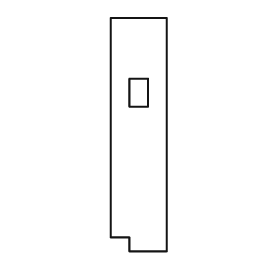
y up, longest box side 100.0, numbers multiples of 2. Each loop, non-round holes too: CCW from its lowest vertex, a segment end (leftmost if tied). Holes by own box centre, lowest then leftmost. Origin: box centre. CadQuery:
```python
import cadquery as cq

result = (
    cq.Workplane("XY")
    .moveTo(-4.0, -50.0)
    .lineTo(12.0, -50.0)
    .lineTo(12.0, 50.0)
    .lineTo(-12.0, 50.0)
    .lineTo(-12.0, -44.0)
    .lineTo(-4.0, -44.0)
    .close()
    .moveTo(-4.0, 12.0)
    .lineTo(4.0, 12.0)
    .lineTo(4.0, 24.0)
    .lineTo(-4.0, 24.0)
    .close()
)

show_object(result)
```